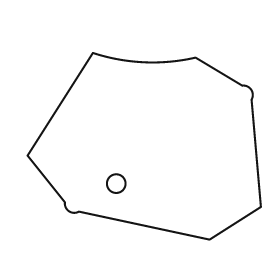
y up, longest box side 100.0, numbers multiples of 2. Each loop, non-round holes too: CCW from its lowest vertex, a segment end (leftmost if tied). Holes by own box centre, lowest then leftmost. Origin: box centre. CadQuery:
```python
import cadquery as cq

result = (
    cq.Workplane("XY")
    .moveTo(28.0, -40.0)
    .lineTo(50.0, -26.0)
    .lineTo(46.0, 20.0)
    .threePointArc((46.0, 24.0), (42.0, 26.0))
    .lineTo(22.0, 38.0)
    .threePointArc((0.0, 36.0), (-22.0, 40.0))
    .lineTo(-50.0, -4.0)
    .lineTo(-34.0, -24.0)
    .threePointArc((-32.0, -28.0), (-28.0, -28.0))
    .close()
    .moveTo(-12.0, -16.0)
    .circle(4.0)
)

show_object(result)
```